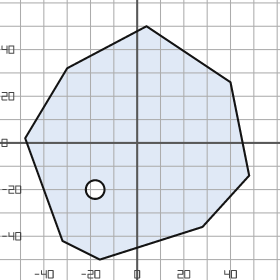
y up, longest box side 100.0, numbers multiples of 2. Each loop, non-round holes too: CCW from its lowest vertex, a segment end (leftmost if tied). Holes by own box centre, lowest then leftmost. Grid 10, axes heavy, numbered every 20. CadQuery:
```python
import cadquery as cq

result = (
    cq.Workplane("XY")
    .moveTo(-16.0, -50.0)
    .lineTo(28.0, -36.0)
    .lineTo(48.0, -14.0)
    .lineTo(40.0, 26.0)
    .lineTo(4.0, 50.0)
    .lineTo(-30.0, 32.0)
    .lineTo(-48.0, 2.0)
    .lineTo(-32.0, -42.0)
    .close()
    .moveTo(-18.0, -20.0)
    .circle(4.0)
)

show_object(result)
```